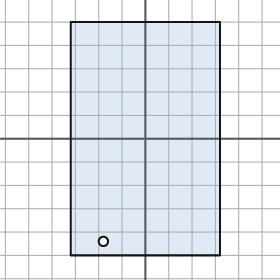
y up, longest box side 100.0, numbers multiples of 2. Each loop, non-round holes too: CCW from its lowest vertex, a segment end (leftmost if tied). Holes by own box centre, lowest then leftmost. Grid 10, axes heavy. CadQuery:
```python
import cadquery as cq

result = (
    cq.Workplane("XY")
    .moveTo(-32.0, -50.0)
    .lineTo(32.0, -50.0)
    .lineTo(32.0, 50.0)
    .lineTo(-32.0, 50.0)
    .close()
    .moveTo(-18.0, -44.0)
    .circle(2.0)
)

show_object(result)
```